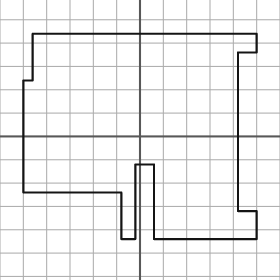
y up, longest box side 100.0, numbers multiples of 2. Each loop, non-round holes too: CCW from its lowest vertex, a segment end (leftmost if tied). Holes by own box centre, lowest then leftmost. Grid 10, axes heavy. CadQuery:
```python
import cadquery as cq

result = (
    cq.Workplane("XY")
    .moveTo(-8.0, -44.0)
    .lineTo(-2.0, -44.0)
    .lineTo(-2.0, -12.0)
    .lineTo(6.0, -12.0)
    .lineTo(6.0, -44.0)
    .lineTo(50.0, -44.0)
    .lineTo(50.0, -32.0)
    .lineTo(42.0, -32.0)
    .lineTo(42.0, 36.0)
    .lineTo(50.0, 36.0)
    .lineTo(50.0, 44.0)
    .lineTo(-46.0, 44.0)
    .lineTo(-46.0, 24.0)
    .lineTo(-50.0, 24.0)
    .lineTo(-50.0, -24.0)
    .lineTo(-8.0, -24.0)
    .close()
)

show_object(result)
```